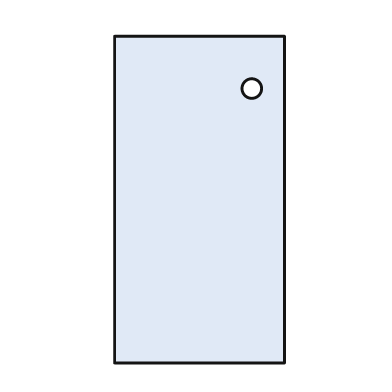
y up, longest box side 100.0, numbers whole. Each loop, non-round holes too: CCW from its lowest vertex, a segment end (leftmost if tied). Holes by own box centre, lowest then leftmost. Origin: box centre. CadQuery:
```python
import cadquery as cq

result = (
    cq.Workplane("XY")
    .moveTo(-26.0, -50.0)
    .lineTo(26.0, -50.0)
    .lineTo(26.0, 50.0)
    .lineTo(-26.0, 50.0)
    .close()
    .moveTo(16.0, 34.0)
    .circle(3.0)
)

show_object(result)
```